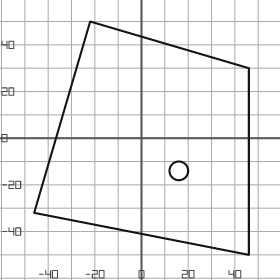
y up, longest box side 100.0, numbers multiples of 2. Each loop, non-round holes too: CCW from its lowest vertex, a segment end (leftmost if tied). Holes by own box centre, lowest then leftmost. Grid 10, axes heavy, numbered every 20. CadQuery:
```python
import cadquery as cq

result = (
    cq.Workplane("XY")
    .moveTo(46.0, -50.0)
    .lineTo(46.0, 30.0)
    .lineTo(-22.0, 50.0)
    .lineTo(-46.0, -32.0)
    .close()
    .moveTo(16.0, -14.0)
    .circle(4.0)
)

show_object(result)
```